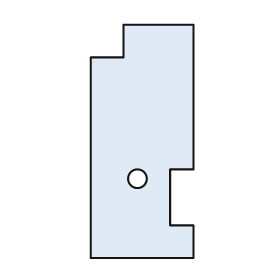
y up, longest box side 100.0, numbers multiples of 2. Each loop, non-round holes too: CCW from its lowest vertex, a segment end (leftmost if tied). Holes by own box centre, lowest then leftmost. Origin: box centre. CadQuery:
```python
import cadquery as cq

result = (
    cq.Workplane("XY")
    .moveTo(-22.0, -50.0)
    .lineTo(22.0, -50.0)
    .lineTo(22.0, -36.0)
    .lineTo(12.0, -36.0)
    .lineTo(12.0, -12.0)
    .lineTo(22.0, -12.0)
    .lineTo(22.0, 50.0)
    .lineTo(-8.0, 50.0)
    .lineTo(-8.0, 36.0)
    .lineTo(-22.0, 36.0)
    .close()
    .moveTo(-2.0, -16.0)
    .circle(4.0)
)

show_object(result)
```